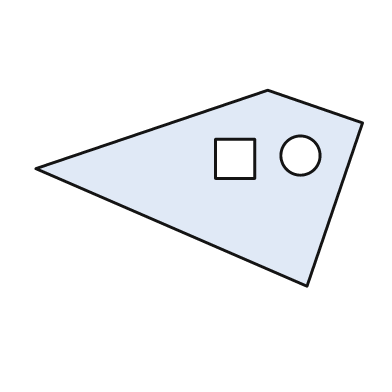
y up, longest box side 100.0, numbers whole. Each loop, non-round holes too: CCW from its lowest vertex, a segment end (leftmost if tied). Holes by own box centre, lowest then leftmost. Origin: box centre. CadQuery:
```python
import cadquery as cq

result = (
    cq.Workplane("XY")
    .moveTo(33.0, -30.0)
    .lineTo(50.0, 20.0)
    .lineTo(21.0, 30.0)
    .lineTo(-50.0, 6.0)
    .close()
    .moveTo(5.0, 3.0)
    .lineTo(17.0, 3.0)
    .lineTo(17.0, 15.0)
    .lineTo(5.0, 15.0)
    .close()
    .moveTo(31.0, 10.0)
    .circle(6.0)
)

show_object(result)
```